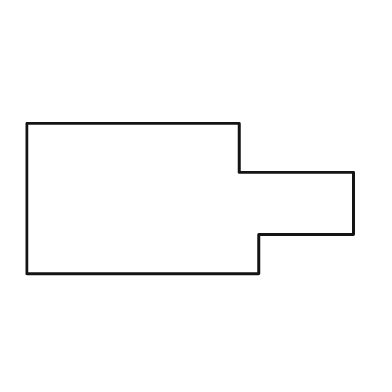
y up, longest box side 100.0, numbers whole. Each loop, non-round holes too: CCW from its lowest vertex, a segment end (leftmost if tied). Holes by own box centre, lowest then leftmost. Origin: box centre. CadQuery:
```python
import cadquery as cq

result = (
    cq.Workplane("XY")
    .moveTo(-50.0, -23.0)
    .lineTo(21.0, -23.0)
    .lineTo(21.0, -11.0)
    .lineTo(50.0, -11.0)
    .lineTo(50.0, 8.0)
    .lineTo(15.0, 8.0)
    .lineTo(15.0, 23.0)
    .lineTo(-50.0, 23.0)
    .close()
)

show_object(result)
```